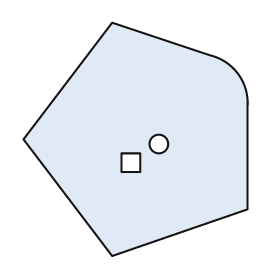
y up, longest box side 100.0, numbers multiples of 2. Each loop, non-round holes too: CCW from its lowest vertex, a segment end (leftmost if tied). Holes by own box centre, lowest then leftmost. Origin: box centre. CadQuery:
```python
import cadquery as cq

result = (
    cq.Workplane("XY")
    .moveTo(-10.0, -50.0)
    .lineTo(48.0, -30.0)
    .lineTo(48.0, 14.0)
    .threePointArc((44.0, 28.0), (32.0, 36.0))
    .lineTo(-10.0, 50.0)
    .lineTo(-48.0, 0.0)
    .close()
    .moveTo(-6.0, -14.0)
    .lineTo(2.0, -14.0)
    .lineTo(2.0, -6.0)
    .lineTo(-6.0, -6.0)
    .close()
    .moveTo(10.0, -2.0)
    .circle(4.0)
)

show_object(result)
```